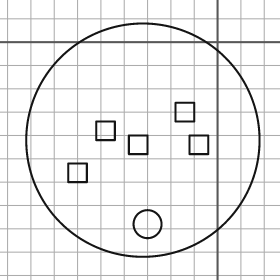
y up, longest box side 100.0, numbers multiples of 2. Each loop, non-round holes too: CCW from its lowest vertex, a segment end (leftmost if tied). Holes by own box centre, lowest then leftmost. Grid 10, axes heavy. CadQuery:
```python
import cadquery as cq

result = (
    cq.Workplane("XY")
    .moveTo(-32.0, -42.0)
    .circle(50.0)
    .moveTo(-30.0, -78.0)
    .circle(6.0)
    .moveTo(-64.0, -60.0)
    .lineTo(-56.0, -60.0)
    .lineTo(-56.0, -52.0)
    .lineTo(-64.0, -52.0)
    .close()
    .moveTo(-38.0, -48.0)
    .lineTo(-30.0, -48.0)
    .lineTo(-30.0, -40.0)
    .lineTo(-38.0, -40.0)
    .close()
    .moveTo(-12.0, -48.0)
    .lineTo(-4.0, -48.0)
    .lineTo(-4.0, -40.0)
    .lineTo(-12.0, -40.0)
    .close()
    .moveTo(-52.0, -42.0)
    .lineTo(-44.0, -42.0)
    .lineTo(-44.0, -34.0)
    .lineTo(-52.0, -34.0)
    .close()
    .moveTo(-18.0, -34.0)
    .lineTo(-10.0, -34.0)
    .lineTo(-10.0, -26.0)
    .lineTo(-18.0, -26.0)
    .close()
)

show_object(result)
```